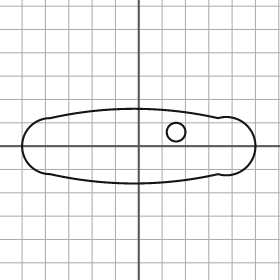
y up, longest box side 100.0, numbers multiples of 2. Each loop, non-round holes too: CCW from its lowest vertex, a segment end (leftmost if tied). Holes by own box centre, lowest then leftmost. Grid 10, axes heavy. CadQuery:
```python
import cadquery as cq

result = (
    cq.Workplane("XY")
    .moveTo(-38.0, -12.0)
    .threePointArc((-2.0, -16.0), (34.0, -12.0))
    .threePointArc((50.0, 0.0), (34.0, 12.0))
    .threePointArc((-2.0, 16.0), (-38.0, 12.0))
    .threePointArc((-50.0, 0.0), (-38.0, -12.0))
    .close()
    .moveTo(16.0, 6.0)
    .circle(4.0)
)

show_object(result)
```